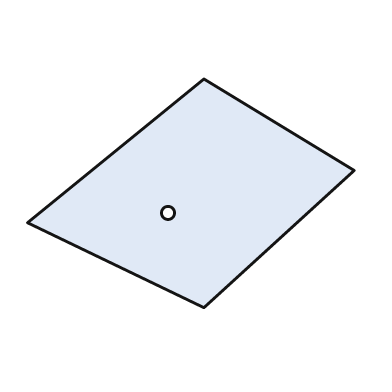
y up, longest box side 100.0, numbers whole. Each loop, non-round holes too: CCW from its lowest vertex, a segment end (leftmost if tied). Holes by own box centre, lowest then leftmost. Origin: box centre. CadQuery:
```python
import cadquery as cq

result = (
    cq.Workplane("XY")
    .moveTo(4.0, -35.0)
    .lineTo(50.0, 7.0)
    .lineTo(4.0, 35.0)
    .lineTo(-50.0, -9.0)
    .close()
    .moveTo(-7.0, -6.0)
    .circle(2.0)
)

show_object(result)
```